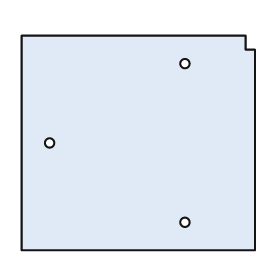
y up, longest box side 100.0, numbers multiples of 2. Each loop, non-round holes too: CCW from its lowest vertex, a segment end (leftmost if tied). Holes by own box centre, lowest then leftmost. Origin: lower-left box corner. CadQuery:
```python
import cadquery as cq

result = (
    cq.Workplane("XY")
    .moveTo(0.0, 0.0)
    .lineTo(100.0, 0.0)
    .lineTo(100.0, 86.0)
    .lineTo(96.0, 86.0)
    .lineTo(96.0, 92.0)
    .lineTo(0.0, 92.0)
    .close()
    .moveTo(70.0, 12.0)
    .circle(2.0)
    .moveTo(12.0, 46.0)
    .circle(2.0)
    .moveTo(70.0, 80.0)
    .circle(2.0)
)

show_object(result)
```